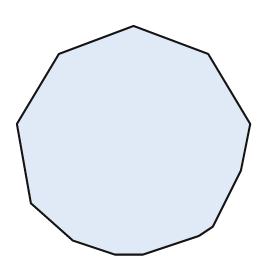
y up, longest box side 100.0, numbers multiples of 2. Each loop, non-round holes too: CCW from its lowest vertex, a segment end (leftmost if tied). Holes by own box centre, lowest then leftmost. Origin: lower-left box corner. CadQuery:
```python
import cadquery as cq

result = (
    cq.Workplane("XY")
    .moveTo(42.0, 0.0)
    .lineTo(54.0, 0.0)
    .lineTo(78.0, 8.0)
    .lineTo(84.0, 12.0)
    .lineTo(96.0, 36.0)
    .lineTo(100.0, 56.0)
    .lineTo(82.0, 86.0)
    .lineTo(50.0, 98.0)
    .lineTo(18.0, 86.0)
    .lineTo(0.0, 56.0)
    .lineTo(6.0, 22.0)
    .lineTo(24.0, 6.0)
    .close()
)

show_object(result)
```